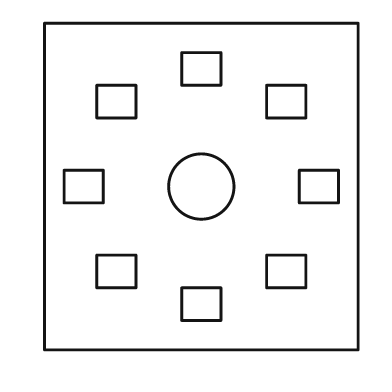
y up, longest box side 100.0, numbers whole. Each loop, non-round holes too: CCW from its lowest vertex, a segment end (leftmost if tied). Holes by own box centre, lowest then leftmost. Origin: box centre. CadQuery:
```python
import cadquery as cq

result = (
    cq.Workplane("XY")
    .moveTo(-48.0, -50.0)
    .lineTo(48.0, -50.0)
    .lineTo(48.0, 50.0)
    .lineTo(-48.0, 50.0)
    .close()
    .moveTo(-6.0, -41.0)
    .lineTo(6.0, -41.0)
    .lineTo(6.0, -31.0)
    .lineTo(-6.0, -31.0)
    .close()
    .moveTo(-32.0, -31.0)
    .lineTo(-20.0, -31.0)
    .lineTo(-20.0, -21.0)
    .lineTo(-32.0, -21.0)
    .close()
    .moveTo(20.0, -31.0)
    .lineTo(32.0, -31.0)
    .lineTo(32.0, -21.0)
    .lineTo(20.0, -21.0)
    .close()
    .moveTo(-42.0, -5.0)
    .lineTo(-30.0, -5.0)
    .lineTo(-30.0, 5.0)
    .lineTo(-42.0, 5.0)
    .close()
    .moveTo(0.0, 0.0)
    .circle(10.0)
    .moveTo(30.0, -5.0)
    .lineTo(42.0, -5.0)
    .lineTo(42.0, 5.0)
    .lineTo(30.0, 5.0)
    .close()
    .moveTo(-32.0, 21.0)
    .lineTo(-20.0, 21.0)
    .lineTo(-20.0, 31.0)
    .lineTo(-32.0, 31.0)
    .close()
    .moveTo(20.0, 21.0)
    .lineTo(32.0, 21.0)
    .lineTo(32.0, 31.0)
    .lineTo(20.0, 31.0)
    .close()
    .moveTo(-6.0, 31.0)
    .lineTo(6.0, 31.0)
    .lineTo(6.0, 41.0)
    .lineTo(-6.0, 41.0)
    .close()
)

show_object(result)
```